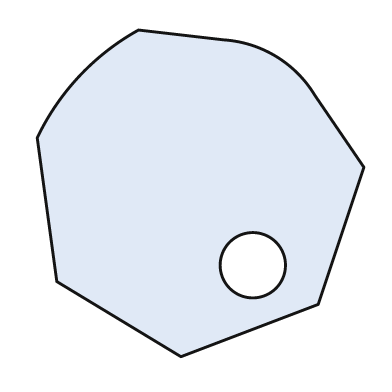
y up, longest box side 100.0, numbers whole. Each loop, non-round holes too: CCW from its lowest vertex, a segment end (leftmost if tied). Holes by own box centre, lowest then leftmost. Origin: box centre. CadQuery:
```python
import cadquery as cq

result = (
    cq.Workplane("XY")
    .moveTo(-6.0, -50.0)
    .lineTo(36.0, -34.0)
    .lineTo(50.0, 8.0)
    .lineTo(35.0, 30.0)
    .threePointArc((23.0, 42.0), (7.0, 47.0))
    .lineTo(-19.0, 50.0)
    .threePointArc((-37.0, 36.0), (-50.0, 17.0))
    .lineTo(-44.0, -27.0)
    .close()
    .moveTo(16.0, -22.0)
    .circle(10.0)
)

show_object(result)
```